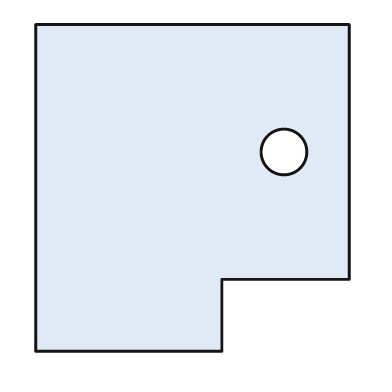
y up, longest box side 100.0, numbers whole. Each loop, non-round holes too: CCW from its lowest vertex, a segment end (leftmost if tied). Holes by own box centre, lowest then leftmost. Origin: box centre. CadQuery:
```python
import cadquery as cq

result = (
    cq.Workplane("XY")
    .moveTo(-48.0, -50.0)
    .lineTo(9.0, -50.0)
    .lineTo(9.0, -28.0)
    .lineTo(48.0, -28.0)
    .lineTo(48.0, 50.0)
    .lineTo(-48.0, 50.0)
    .close()
    .moveTo(28.0, 11.0)
    .circle(7.0)
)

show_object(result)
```